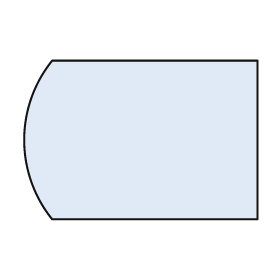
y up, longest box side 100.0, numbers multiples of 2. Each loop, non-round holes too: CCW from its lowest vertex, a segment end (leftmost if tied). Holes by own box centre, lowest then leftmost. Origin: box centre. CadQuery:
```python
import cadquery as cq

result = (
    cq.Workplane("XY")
    .moveTo(-38.0, -34.0)
    .lineTo(50.0, -34.0)
    .lineTo(50.0, 34.0)
    .lineTo(-38.0, 34.0)
    .threePointArc((-50.0, 0.0), (-38.0, -34.0))
    .close()
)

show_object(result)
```